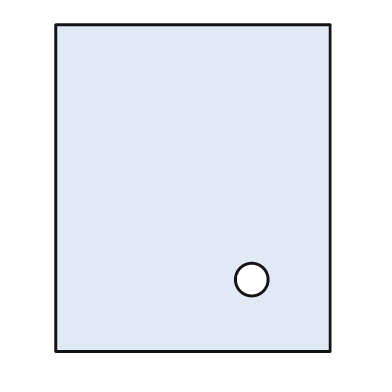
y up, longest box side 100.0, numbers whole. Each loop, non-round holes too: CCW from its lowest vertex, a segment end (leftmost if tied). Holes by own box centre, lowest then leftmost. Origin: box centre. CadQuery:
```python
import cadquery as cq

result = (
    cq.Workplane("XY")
    .moveTo(-42.0, -50.0)
    .lineTo(42.0, -50.0)
    .lineTo(42.0, 50.0)
    .lineTo(-42.0, 50.0)
    .close()
    .moveTo(18.0, -28.0)
    .circle(5.0)
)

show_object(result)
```